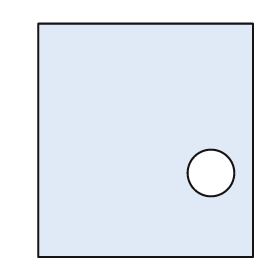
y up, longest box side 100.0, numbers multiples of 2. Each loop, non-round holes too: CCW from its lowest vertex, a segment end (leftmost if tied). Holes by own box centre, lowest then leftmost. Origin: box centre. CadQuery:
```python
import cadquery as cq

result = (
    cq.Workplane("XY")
    .moveTo(-46.0, -50.0)
    .lineTo(46.0, -50.0)
    .lineTo(46.0, 50.0)
    .lineTo(-46.0, 50.0)
    .close()
    .moveTo(28.0, -14.0)
    .circle(10.0)
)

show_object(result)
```